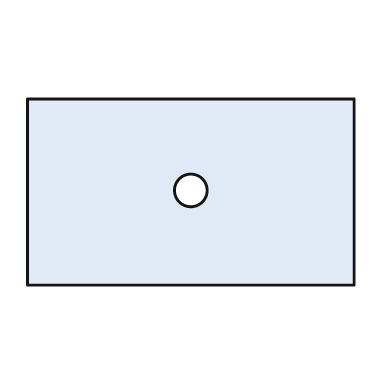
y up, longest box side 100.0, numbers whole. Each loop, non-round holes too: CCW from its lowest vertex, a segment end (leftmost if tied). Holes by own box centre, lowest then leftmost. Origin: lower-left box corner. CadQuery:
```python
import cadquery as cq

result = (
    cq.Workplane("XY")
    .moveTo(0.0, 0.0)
    .lineTo(100.0, 0.0)
    .lineTo(100.0, 57.0)
    .lineTo(0.0, 57.0)
    .close()
    .moveTo(50.0, 29.0)
    .circle(5.0)
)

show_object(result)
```